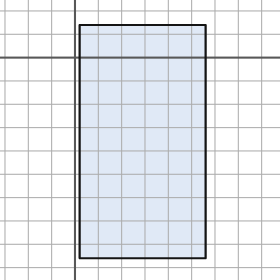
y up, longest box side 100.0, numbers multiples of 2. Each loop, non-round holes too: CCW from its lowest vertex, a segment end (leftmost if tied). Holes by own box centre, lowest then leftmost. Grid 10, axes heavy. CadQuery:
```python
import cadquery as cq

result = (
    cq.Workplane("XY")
    .moveTo(2.0, -86.0)
    .lineTo(56.0, -86.0)
    .lineTo(56.0, 14.0)
    .lineTo(2.0, 14.0)
    .close()
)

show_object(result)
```